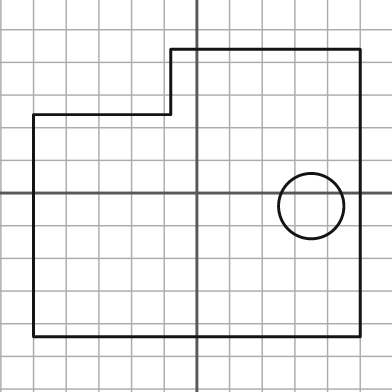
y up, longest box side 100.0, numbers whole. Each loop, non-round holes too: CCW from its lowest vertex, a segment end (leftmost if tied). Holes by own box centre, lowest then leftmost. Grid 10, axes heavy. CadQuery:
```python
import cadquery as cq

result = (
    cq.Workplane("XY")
    .moveTo(-50.0, -44.0)
    .lineTo(50.0, -44.0)
    .lineTo(50.0, 44.0)
    .lineTo(-8.0, 44.0)
    .lineTo(-8.0, 24.0)
    .lineTo(-50.0, 24.0)
    .close()
    .moveTo(35.0, -4.0)
    .circle(10.0)
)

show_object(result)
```